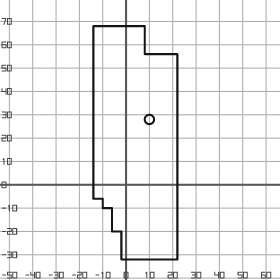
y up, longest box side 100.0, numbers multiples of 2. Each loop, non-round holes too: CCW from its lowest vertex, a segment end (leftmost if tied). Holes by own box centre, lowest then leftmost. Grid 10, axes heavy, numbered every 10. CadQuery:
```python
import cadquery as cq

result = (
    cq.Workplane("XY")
    .moveTo(-2.0, -32.0)
    .lineTo(22.0, -32.0)
    .lineTo(22.0, 56.0)
    .lineTo(8.0, 56.0)
    .lineTo(8.0, 68.0)
    .lineTo(-14.0, 68.0)
    .lineTo(-14.0, -6.0)
    .lineTo(-10.0, -6.0)
    .lineTo(-10.0, -10.0)
    .lineTo(-6.0, -10.0)
    .lineTo(-6.0, -20.0)
    .lineTo(-2.0, -20.0)
    .close()
    .moveTo(10.0, 28.0)
    .circle(2.0)
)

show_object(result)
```